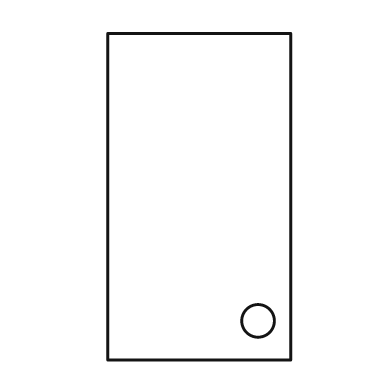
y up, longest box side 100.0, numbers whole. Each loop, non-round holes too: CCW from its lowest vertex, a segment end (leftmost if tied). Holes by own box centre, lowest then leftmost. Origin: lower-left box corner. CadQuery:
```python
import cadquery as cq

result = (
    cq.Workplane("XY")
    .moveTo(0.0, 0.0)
    .lineTo(56.0, 0.0)
    .lineTo(56.0, 100.0)
    .lineTo(0.0, 100.0)
    .close()
    .moveTo(46.0, 12.0)
    .circle(5.0)
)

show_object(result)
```